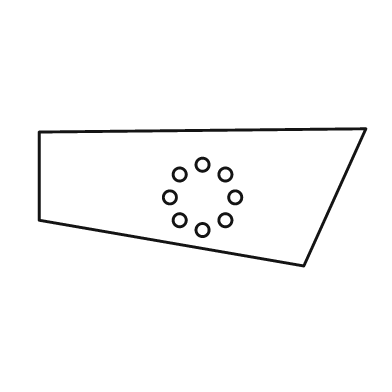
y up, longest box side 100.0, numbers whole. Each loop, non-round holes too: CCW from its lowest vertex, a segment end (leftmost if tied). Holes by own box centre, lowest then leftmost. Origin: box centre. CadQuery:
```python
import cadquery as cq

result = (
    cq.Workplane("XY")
    .moveTo(31.0, -21.0)
    .lineTo(50.0, 21.0)
    .lineTo(-50.0, 20.0)
    .lineTo(-50.0, -7.0)
    .close()
    .moveTo(0.0, -10.0)
    .circle(2.0)
    .moveTo(-7.0, -7.0)
    .circle(2.0)
    .moveTo(7.0, -7.0)
    .circle(2.0)
    .moveTo(-10.0, 0.0)
    .circle(2.0)
    .moveTo(10.0, 0.0)
    .circle(2.0)
    .moveTo(-7.0, 7.0)
    .circle(2.0)
    .moveTo(7.0, 7.0)
    .circle(2.0)
    .moveTo(0.0, 10.0)
    .circle(2.0)
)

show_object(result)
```